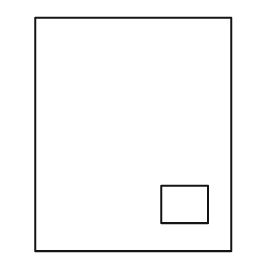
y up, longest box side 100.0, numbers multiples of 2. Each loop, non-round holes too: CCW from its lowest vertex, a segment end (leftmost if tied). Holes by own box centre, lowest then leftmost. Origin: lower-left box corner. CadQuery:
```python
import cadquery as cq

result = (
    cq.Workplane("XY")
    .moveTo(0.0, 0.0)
    .lineTo(84.0, 0.0)
    .lineTo(84.0, 100.0)
    .lineTo(0.0, 100.0)
    .close()
    .moveTo(54.0, 12.0)
    .lineTo(74.0, 12.0)
    .lineTo(74.0, 28.0)
    .lineTo(54.0, 28.0)
    .close()
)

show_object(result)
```